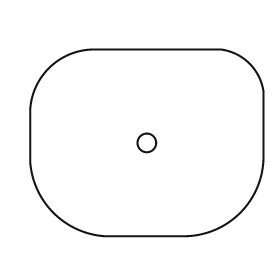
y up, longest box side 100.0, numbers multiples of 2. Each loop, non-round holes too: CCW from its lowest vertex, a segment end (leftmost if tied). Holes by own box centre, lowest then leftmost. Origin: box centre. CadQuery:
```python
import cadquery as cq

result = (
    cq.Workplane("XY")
    .moveTo(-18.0, -40.0)
    .lineTo(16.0, -40.0)
    .threePointArc((40.0, -30.0), (50.0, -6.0))
    .lineTo(50.0, 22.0)
    .threePointArc((44.0, 34.0), (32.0, 40.0))
    .lineTo(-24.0, 40.0)
    .threePointArc((-42.0, 32.0), (-50.0, 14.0))
    .lineTo(-50.0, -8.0)
    .threePointArc((-40.0, -30.0), (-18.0, -40.0))
    .close()
    .moveTo(0.0, 0.0)
    .circle(4.0)
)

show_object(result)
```